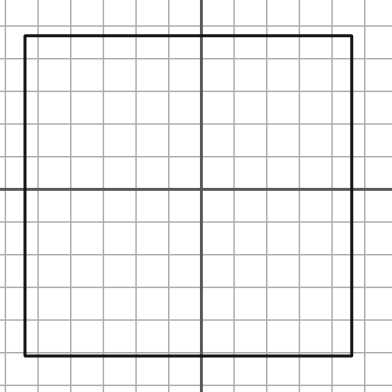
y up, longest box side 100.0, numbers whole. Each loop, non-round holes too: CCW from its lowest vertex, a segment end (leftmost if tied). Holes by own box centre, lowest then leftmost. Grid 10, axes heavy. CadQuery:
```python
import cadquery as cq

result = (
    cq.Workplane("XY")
    .moveTo(-54.0, -51.0)
    .lineTo(46.0, -51.0)
    .lineTo(46.0, 47.0)
    .lineTo(-54.0, 47.0)
    .close()
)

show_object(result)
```